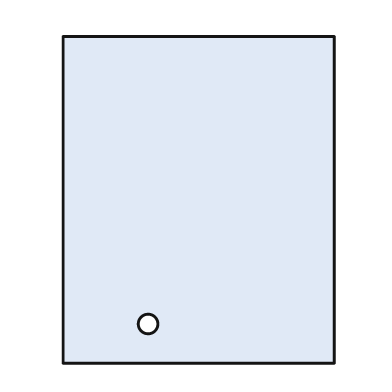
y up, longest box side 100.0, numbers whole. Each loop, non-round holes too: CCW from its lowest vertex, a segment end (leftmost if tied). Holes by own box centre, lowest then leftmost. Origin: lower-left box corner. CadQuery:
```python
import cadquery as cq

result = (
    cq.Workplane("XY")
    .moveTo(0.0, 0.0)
    .lineTo(83.0, 0.0)
    .lineTo(83.0, 100.0)
    .lineTo(0.0, 100.0)
    .close()
    .moveTo(26.0, 12.0)
    .circle(3.0)
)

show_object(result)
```